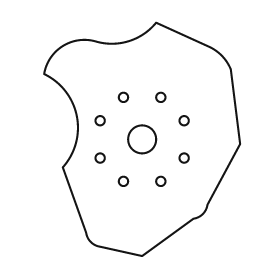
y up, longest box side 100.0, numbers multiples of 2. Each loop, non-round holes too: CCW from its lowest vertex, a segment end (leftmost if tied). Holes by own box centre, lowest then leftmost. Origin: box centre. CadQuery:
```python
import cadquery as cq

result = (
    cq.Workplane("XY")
    .moveTo(0.0, -50.0)
    .lineTo(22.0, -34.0)
    .threePointArc((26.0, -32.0), (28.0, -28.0))
    .lineTo(42.0, -2.0)
    .lineTo(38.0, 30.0)
    .threePointArc((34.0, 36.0), (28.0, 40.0))
    .lineTo(6.0, 50.0)
    .threePointArc((-6.0, 42.0), (-20.0, 42.0))
    .threePointArc((-34.0, 40.0), (-42.0, 28.0))
    .threePointArc((-28.0, 10.0), (-34.0, -12.0))
    .lineTo(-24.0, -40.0)
    .threePointArc((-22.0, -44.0), (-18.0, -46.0))
    .close()
    .moveTo(-8.0, -18.0)
    .circle(2.0)
    .moveTo(8.0, -18.0)
    .circle(2.0)
    .moveTo(-18.0, -8.0)
    .circle(2.0)
    .moveTo(18.0, -8.0)
    .circle(2.0)
    .moveTo(0.0, 0.0)
    .circle(6.0)
    .moveTo(-18.0, 8.0)
    .circle(2.0)
    .moveTo(18.0, 8.0)
    .circle(2.0)
    .moveTo(-8.0, 18.0)
    .circle(2.0)
    .moveTo(8.0, 18.0)
    .circle(2.0)
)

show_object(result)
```